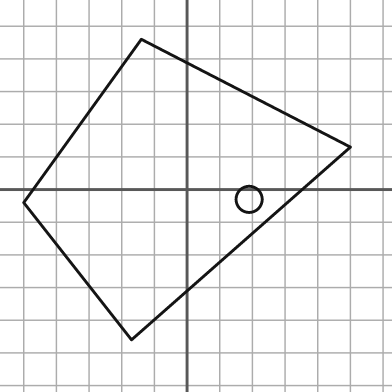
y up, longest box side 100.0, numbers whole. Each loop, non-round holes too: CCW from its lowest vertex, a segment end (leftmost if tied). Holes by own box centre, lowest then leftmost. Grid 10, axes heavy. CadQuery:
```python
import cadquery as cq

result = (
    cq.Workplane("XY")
    .moveTo(-17.0, -46.0)
    .lineTo(50.0, 13.0)
    .lineTo(-14.0, 46.0)
    .lineTo(-50.0, -4.0)
    .close()
    .moveTo(19.0, -3.0)
    .circle(4.0)
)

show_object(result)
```